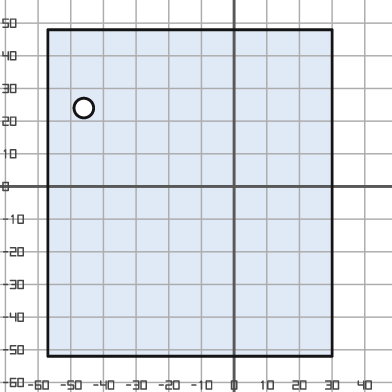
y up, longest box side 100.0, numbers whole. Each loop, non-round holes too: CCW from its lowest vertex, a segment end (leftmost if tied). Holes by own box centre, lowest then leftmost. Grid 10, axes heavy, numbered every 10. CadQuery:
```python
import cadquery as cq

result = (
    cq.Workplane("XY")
    .moveTo(-57.0, -52.0)
    .lineTo(30.0, -52.0)
    .lineTo(30.0, 48.0)
    .lineTo(-57.0, 48.0)
    .close()
    .moveTo(-46.0, 24.0)
    .circle(3.0)
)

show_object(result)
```